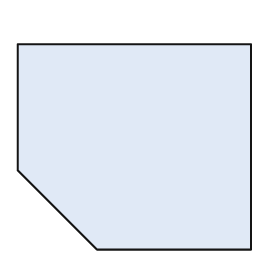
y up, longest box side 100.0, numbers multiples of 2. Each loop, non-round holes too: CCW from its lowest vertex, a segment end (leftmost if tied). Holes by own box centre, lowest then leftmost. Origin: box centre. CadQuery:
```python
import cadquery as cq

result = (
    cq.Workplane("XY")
    .moveTo(-16.0, -44.0)
    .lineTo(50.0, -44.0)
    .lineTo(50.0, 44.0)
    .lineTo(-50.0, 44.0)
    .lineTo(-50.0, -10.0)
    .close()
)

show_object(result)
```